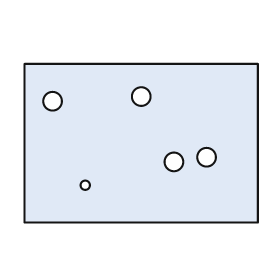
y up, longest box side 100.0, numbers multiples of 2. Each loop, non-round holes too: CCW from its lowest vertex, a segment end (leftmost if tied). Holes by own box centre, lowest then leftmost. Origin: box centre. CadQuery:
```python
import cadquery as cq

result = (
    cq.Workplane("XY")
    .moveTo(-50.0, -34.0)
    .lineTo(50.0, -34.0)
    .lineTo(50.0, 34.0)
    .lineTo(-50.0, 34.0)
    .close()
    .moveTo(-24.0, -18.0)
    .circle(2.0)
    .moveTo(14.0, -8.0)
    .circle(4.0)
    .moveTo(28.0, -6.0)
    .circle(4.0)
    .moveTo(-38.0, 18.0)
    .circle(4.0)
    .moveTo(0.0, 20.0)
    .circle(4.0)
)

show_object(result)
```